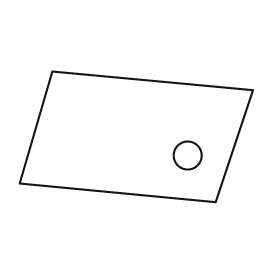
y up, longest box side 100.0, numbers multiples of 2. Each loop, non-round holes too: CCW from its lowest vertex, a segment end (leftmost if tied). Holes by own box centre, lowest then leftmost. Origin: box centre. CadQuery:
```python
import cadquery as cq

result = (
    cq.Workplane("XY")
    .moveTo(34.0, -28.0)
    .lineTo(50.0, 20.0)
    .lineTo(-36.0, 28.0)
    .lineTo(-50.0, -20.0)
    .close()
    .moveTo(22.0, -8.0)
    .circle(6.0)
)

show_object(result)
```